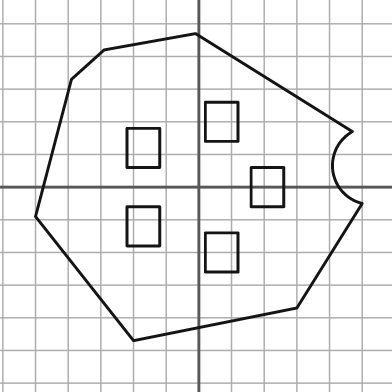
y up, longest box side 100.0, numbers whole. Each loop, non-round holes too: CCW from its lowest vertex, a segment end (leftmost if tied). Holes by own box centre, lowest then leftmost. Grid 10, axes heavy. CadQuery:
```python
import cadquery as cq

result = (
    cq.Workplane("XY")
    .moveTo(-20.0, -47.0)
    .lineTo(30.0, -37.0)
    .lineTo(50.0, -5.0)
    .threePointArc((41.0, 5.0), (47.0, 17.0))
    .lineTo(-1.0, 47.0)
    .lineTo(-29.0, 42.0)
    .lineTo(-39.0, 33.0)
    .lineTo(-50.0, -9.0)
    .close()
    .moveTo(2.0, -26.0)
    .lineTo(12.0, -26.0)
    .lineTo(12.0, -14.0)
    .lineTo(2.0, -14.0)
    .close()
    .moveTo(-22.0, -18.0)
    .lineTo(-12.0, -18.0)
    .lineTo(-12.0, -6.0)
    .lineTo(-22.0, -6.0)
    .close()
    .moveTo(16.0, -6.0)
    .lineTo(26.0, -6.0)
    .lineTo(26.0, 6.0)
    .lineTo(16.0, 6.0)
    .close()
    .moveTo(-22.0, 6.0)
    .lineTo(-12.0, 6.0)
    .lineTo(-12.0, 18.0)
    .lineTo(-22.0, 18.0)
    .close()
    .moveTo(2.0, 14.0)
    .lineTo(12.0, 14.0)
    .lineTo(12.0, 26.0)
    .lineTo(2.0, 26.0)
    .close()
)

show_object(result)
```